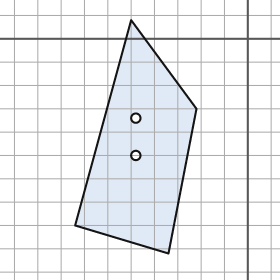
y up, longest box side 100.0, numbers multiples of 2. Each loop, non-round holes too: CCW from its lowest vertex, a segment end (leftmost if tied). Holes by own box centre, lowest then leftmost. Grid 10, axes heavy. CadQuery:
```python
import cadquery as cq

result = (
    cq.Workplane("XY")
    .moveTo(-34.0, -92.0)
    .lineTo(-22.0, -30.0)
    .lineTo(-50.0, 8.0)
    .lineTo(-74.0, -80.0)
    .close()
    .moveTo(-48.0, -50.0)
    .circle(2.0)
    .moveTo(-48.0, -34.0)
    .circle(2.0)
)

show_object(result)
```